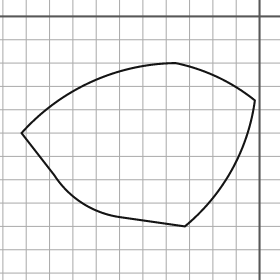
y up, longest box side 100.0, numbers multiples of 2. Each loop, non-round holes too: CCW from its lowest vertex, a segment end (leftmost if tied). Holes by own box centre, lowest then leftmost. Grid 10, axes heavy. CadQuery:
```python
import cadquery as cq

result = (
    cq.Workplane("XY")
    .moveTo(-32.0, -90.0)
    .threePointArc((-12.0, -66.0), (-2.0, -36.0))
    .threePointArc((-18.0, -26.0), (-36.0, -20.0))
    .threePointArc((-72.0, -28.0), (-102.0, -50.0))
    .lineTo(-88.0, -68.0)
    .threePointArc((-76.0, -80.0), (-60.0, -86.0))
    .close()
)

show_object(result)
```